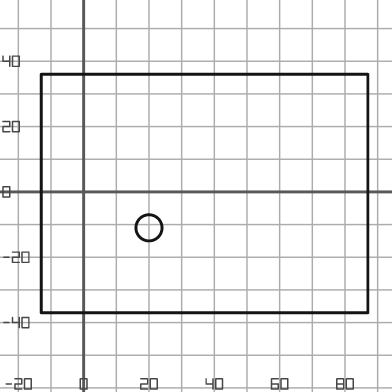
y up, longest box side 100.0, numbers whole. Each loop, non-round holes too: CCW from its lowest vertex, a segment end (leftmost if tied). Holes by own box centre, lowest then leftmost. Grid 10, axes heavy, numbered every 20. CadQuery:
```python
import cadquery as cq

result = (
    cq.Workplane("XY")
    .moveTo(-13.0, -37.0)
    .lineTo(87.0, -37.0)
    .lineTo(87.0, 36.0)
    .lineTo(-13.0, 36.0)
    .close()
    .moveTo(20.0, -11.0)
    .circle(4.0)
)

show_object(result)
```